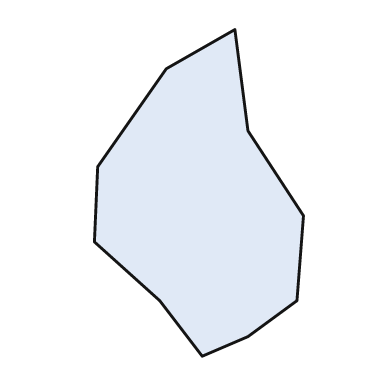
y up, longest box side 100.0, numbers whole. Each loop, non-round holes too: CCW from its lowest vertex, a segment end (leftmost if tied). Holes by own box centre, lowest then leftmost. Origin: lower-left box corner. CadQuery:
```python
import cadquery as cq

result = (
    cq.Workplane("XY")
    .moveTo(33.0, 0.0)
    .lineTo(47.0, 6.0)
    .lineTo(62.0, 17.0)
    .lineTo(64.0, 43.0)
    .lineTo(47.0, 69.0)
    .lineTo(43.0, 100.0)
    .lineTo(22.0, 88.0)
    .lineTo(1.0, 58.0)
    .lineTo(0.0, 35.0)
    .lineTo(20.0, 17.0)
    .close()
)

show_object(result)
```